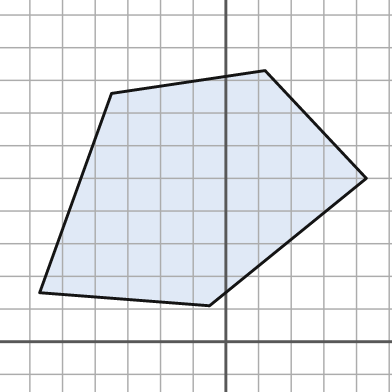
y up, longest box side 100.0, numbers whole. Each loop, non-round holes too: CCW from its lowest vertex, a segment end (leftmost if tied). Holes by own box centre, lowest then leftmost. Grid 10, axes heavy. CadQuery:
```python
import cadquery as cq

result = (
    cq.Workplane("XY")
    .moveTo(-5.0, 11.0)
    .lineTo(43.0, 50.0)
    .lineTo(12.0, 83.0)
    .lineTo(-35.0, 76.0)
    .lineTo(-57.0, 15.0)
    .close()
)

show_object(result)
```